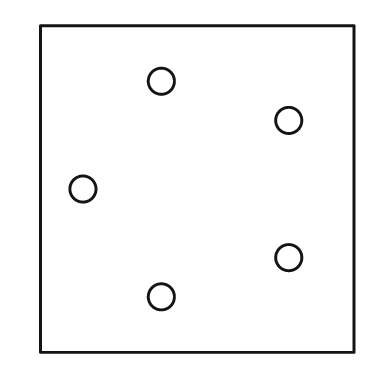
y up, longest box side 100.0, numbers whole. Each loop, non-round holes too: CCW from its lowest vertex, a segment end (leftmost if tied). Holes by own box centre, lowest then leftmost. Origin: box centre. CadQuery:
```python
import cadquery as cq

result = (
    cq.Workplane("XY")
    .moveTo(-48.0, -50.0)
    .lineTo(48.0, -50.0)
    .lineTo(48.0, 50.0)
    .lineTo(-48.0, 50.0)
    .close()
    .moveTo(-11.0, -33.0)
    .circle(4.0)
    .moveTo(28.0, -21.0)
    .circle(4.0)
    .moveTo(-35.0, 0.0)
    .circle(4.0)
    .moveTo(28.0, 21.0)
    .circle(4.0)
    .moveTo(-11.0, 33.0)
    .circle(4.0)
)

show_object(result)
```